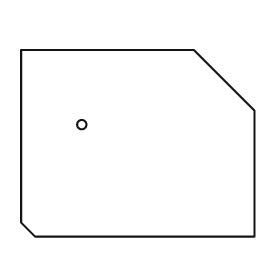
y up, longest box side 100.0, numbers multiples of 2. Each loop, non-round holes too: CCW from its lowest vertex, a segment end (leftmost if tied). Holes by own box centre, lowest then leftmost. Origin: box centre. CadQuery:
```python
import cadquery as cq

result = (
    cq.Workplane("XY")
    .moveTo(-44.0, -40.0)
    .lineTo(50.0, -40.0)
    .lineTo(50.0, 14.0)
    .lineTo(24.0, 40.0)
    .lineTo(-50.0, 40.0)
    .lineTo(-50.0, -34.0)
    .close()
    .moveTo(-24.0, 8.0)
    .circle(2.0)
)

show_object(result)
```